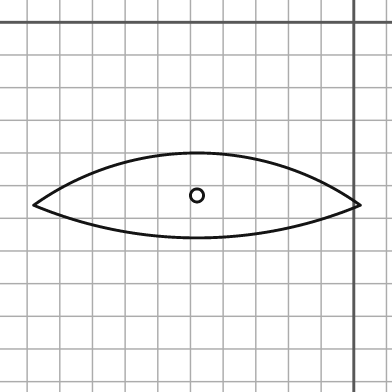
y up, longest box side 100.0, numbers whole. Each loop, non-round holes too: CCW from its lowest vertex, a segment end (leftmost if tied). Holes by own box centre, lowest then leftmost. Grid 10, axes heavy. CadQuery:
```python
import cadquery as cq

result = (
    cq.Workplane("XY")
    .moveTo(-98.0, -56.0)
    .threePointArc((-48.0, -66.0), (2.0, -56.0))
    .threePointArc((-48.0, -40.0), (-98.0, -56.0))
    .close()
    .moveTo(-48.0, -53.0)
    .circle(2.0)
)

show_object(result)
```